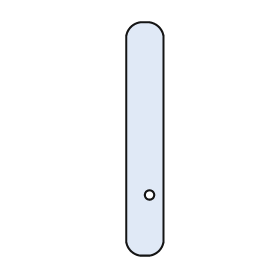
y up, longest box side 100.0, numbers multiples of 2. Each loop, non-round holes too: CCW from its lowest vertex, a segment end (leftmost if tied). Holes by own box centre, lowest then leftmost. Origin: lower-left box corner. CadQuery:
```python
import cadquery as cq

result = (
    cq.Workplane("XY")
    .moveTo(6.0, 0.0)
    .lineTo(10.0, 0.0)
    .threePointArc((14.0, 2.0), (16.0, 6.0))
    .lineTo(16.0, 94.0)
    .threePointArc((14.0, 98.0), (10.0, 100.0))
    .lineTo(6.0, 100.0)
    .threePointArc((2.0, 98.0), (0.0, 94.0))
    .lineTo(0.0, 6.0)
    .threePointArc((2.0, 2.0), (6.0, 0.0))
    .close()
    .moveTo(10.0, 26.0)
    .circle(2.0)
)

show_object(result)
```